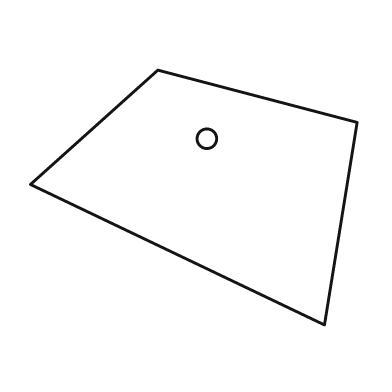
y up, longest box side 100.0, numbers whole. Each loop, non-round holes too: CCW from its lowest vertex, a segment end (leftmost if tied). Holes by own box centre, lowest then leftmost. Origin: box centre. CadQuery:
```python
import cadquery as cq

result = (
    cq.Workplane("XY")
    .moveTo(40.0, -39.0)
    .lineTo(50.0, 23.0)
    .lineTo(-11.0, 39.0)
    .lineTo(-50.0, 4.0)
    .close()
    .moveTo(4.0, 18.0)
    .circle(3.0)
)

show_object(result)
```